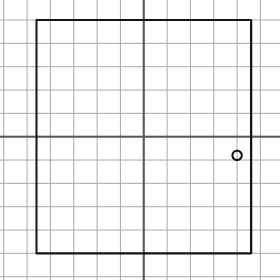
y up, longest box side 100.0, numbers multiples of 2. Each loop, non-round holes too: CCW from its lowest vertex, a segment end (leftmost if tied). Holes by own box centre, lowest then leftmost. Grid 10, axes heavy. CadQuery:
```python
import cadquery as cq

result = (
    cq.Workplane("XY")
    .moveTo(-46.0, -50.0)
    .lineTo(46.0, -50.0)
    .lineTo(46.0, 50.0)
    .lineTo(-46.0, 50.0)
    .close()
    .moveTo(40.0, -8.0)
    .circle(2.0)
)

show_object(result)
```